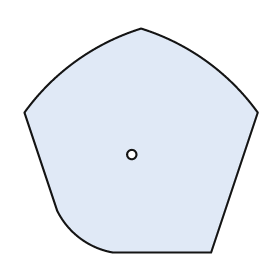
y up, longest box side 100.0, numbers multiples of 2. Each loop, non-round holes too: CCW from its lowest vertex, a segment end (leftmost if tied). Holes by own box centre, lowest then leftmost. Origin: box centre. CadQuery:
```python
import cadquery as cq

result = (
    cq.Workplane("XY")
    .moveTo(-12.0, -48.0)
    .lineTo(30.0, -48.0)
    .lineTo(50.0, 12.0)
    .threePointArc((28.0, 34.0), (0.0, 48.0))
    .threePointArc((-28.0, 34.0), (-50.0, 12.0))
    .lineTo(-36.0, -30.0)
    .threePointArc((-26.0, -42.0), (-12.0, -48.0))
    .close()
    .moveTo(-4.0, -6.0)
    .circle(2.0)
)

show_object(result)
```